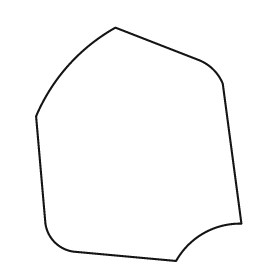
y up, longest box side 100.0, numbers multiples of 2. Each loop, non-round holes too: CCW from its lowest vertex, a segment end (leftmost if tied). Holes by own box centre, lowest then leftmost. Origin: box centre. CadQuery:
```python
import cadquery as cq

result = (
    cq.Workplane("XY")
    .moveTo(16.0, -50.0)
    .threePointArc((28.0, -38.0), (44.0, -34.0))
    .lineTo(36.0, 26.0)
    .threePointArc((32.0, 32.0), (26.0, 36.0))
    .lineTo(-10.0, 50.0)
    .threePointArc((-30.0, 34.0), (-44.0, 12.0))
    .lineTo(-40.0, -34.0)
    .threePointArc((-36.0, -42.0), (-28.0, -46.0))
    .close()
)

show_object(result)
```